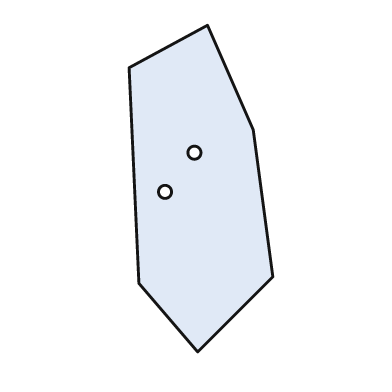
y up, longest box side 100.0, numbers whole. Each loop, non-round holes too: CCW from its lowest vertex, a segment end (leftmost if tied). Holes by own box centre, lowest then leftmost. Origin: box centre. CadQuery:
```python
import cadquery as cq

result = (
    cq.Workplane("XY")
    .moveTo(-1.0, -50.0)
    .lineTo(22.0, -27.0)
    .lineTo(16.0, 18.0)
    .lineTo(2.0, 50.0)
    .lineTo(-22.0, 37.0)
    .lineTo(-19.0, -29.0)
    .close()
    .moveTo(-11.0, -1.0)
    .circle(2.0)
    .moveTo(-2.0, 11.0)
    .circle(2.0)
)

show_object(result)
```